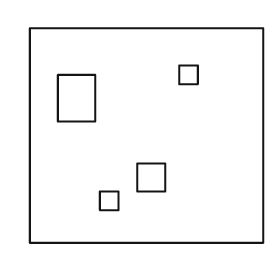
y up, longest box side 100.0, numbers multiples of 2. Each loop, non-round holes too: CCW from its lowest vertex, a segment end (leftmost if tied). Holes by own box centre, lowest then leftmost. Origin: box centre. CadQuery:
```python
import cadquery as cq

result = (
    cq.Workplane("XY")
    .moveTo(-50.0, -46.0)
    .lineTo(50.0, -46.0)
    .lineTo(50.0, 46.0)
    .lineTo(-50.0, 46.0)
    .close()
    .moveTo(-20.0, -32.0)
    .lineTo(-12.0, -32.0)
    .lineTo(-12.0, -24.0)
    .lineTo(-20.0, -24.0)
    .close()
    .moveTo(-4.0, -24.0)
    .lineTo(8.0, -24.0)
    .lineTo(8.0, -12.0)
    .lineTo(-4.0, -12.0)
    .close()
    .moveTo(-38.0, 6.0)
    .lineTo(-22.0, 6.0)
    .lineTo(-22.0, 26.0)
    .lineTo(-38.0, 26.0)
    .close()
    .moveTo(14.0, 22.0)
    .lineTo(22.0, 22.0)
    .lineTo(22.0, 30.0)
    .lineTo(14.0, 30.0)
    .close()
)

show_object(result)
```